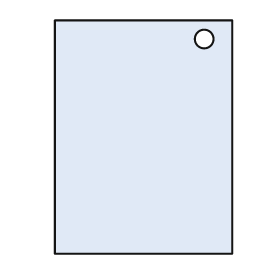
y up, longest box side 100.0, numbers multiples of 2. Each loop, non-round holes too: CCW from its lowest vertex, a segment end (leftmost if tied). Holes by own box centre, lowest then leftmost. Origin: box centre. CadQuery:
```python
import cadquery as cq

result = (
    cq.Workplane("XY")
    .moveTo(-38.0, -50.0)
    .lineTo(38.0, -50.0)
    .lineTo(38.0, 50.0)
    .lineTo(-38.0, 50.0)
    .close()
    .moveTo(26.0, 42.0)
    .circle(4.0)
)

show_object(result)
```